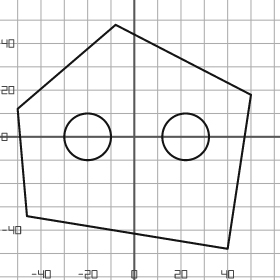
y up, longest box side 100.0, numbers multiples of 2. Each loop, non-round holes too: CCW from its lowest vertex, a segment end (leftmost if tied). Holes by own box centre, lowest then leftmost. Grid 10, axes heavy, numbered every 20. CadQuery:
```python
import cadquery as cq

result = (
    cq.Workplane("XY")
    .moveTo(40.0, -48.0)
    .lineTo(50.0, 18.0)
    .lineTo(-8.0, 48.0)
    .lineTo(-50.0, 12.0)
    .lineTo(-46.0, -34.0)
    .close()
    .moveTo(-20.0, 0.0)
    .circle(10.0)
    .moveTo(22.0, 0.0)
    .circle(10.0)
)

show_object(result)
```